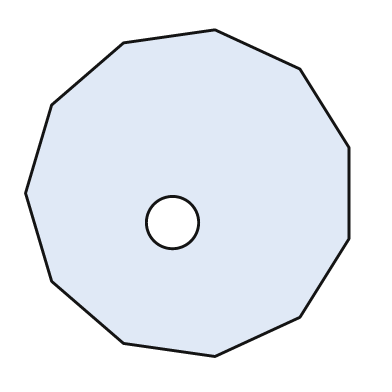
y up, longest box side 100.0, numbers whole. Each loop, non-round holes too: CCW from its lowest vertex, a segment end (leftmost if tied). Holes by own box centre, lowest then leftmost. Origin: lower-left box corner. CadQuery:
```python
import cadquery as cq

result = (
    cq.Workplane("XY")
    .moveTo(58.0, 0.0)
    .lineTo(84.0, 12.0)
    .lineTo(99.0, 36.0)
    .lineTo(99.0, 64.0)
    .lineTo(84.0, 88.0)
    .lineTo(58.0, 100.0)
    .lineTo(30.0, 96.0)
    .lineTo(8.0, 77.0)
    .lineTo(0.0, 50.0)
    .lineTo(8.0, 23.0)
    .lineTo(30.0, 4.0)
    .close()
    .moveTo(45.0, 41.0)
    .circle(8.0)
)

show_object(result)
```